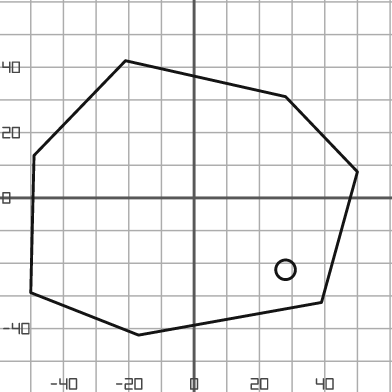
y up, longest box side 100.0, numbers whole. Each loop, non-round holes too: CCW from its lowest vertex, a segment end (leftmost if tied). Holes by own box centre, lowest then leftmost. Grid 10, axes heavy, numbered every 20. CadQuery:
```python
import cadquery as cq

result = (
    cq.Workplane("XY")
    .moveTo(-17.0, -42.0)
    .lineTo(39.0, -32.0)
    .lineTo(50.0, 8.0)
    .lineTo(28.0, 31.0)
    .lineTo(-21.0, 42.0)
    .lineTo(-49.0, 13.0)
    .lineTo(-50.0, -29.0)
    .close()
    .moveTo(28.0, -22.0)
    .circle(3.0)
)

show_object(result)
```